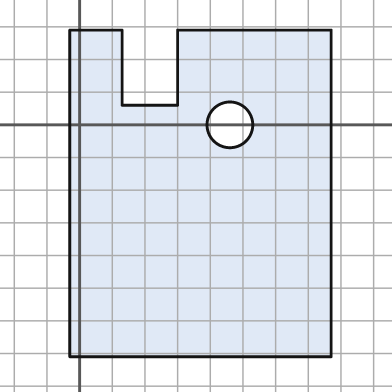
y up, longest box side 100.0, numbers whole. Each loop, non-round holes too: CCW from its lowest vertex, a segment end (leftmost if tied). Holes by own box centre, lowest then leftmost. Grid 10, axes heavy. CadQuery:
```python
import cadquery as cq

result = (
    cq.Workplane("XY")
    .moveTo(-3.0, -71.0)
    .lineTo(77.0, -71.0)
    .lineTo(77.0, 29.0)
    .lineTo(30.0, 29.0)
    .lineTo(30.0, 6.0)
    .lineTo(13.0, 6.0)
    .lineTo(13.0, 29.0)
    .lineTo(-3.0, 29.0)
    .close()
    .moveTo(46.0, 0.0)
    .circle(7.0)
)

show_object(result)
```